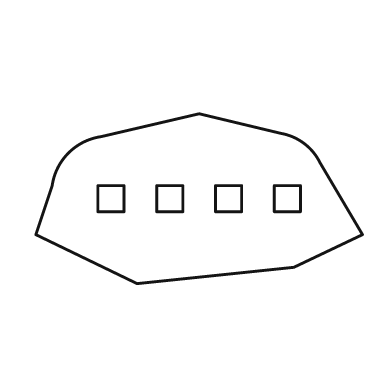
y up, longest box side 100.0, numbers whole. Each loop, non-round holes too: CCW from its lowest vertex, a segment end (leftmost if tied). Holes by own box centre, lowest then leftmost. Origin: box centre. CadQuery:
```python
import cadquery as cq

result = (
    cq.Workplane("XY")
    .moveTo(-19.0, -26.0)
    .lineTo(29.0, -21.0)
    .lineTo(50.0, -11.0)
    .lineTo(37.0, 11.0)
    .threePointArc((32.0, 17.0), (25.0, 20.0))
    .lineTo(0.0, 26.0)
    .lineTo(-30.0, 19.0)
    .threePointArc((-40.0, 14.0), (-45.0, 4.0))
    .lineTo(-50.0, -11.0)
    .close()
    .moveTo(-31.0, -4.0)
    .lineTo(-23.0, -4.0)
    .lineTo(-23.0, 4.0)
    .lineTo(-31.0, 4.0)
    .close()
    .moveTo(-13.0, -4.0)
    .lineTo(-5.0, -4.0)
    .lineTo(-5.0, 4.0)
    .lineTo(-13.0, 4.0)
    .close()
    .moveTo(5.0, -4.0)
    .lineTo(13.0, -4.0)
    .lineTo(13.0, 4.0)
    .lineTo(5.0, 4.0)
    .close()
    .moveTo(23.0, -4.0)
    .lineTo(31.0, -4.0)
    .lineTo(31.0, 4.0)
    .lineTo(23.0, 4.0)
    .close()
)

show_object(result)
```